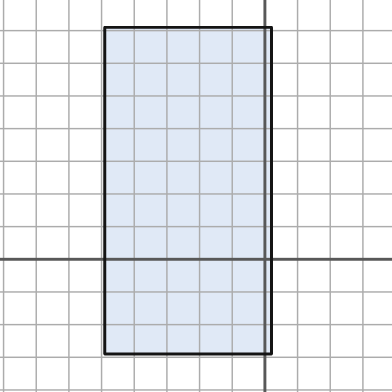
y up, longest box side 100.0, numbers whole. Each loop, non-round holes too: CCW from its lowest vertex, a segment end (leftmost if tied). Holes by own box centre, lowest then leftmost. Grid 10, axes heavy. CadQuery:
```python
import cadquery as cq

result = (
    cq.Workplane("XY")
    .moveTo(-49.0, -29.0)
    .lineTo(2.0, -29.0)
    .lineTo(2.0, 71.0)
    .lineTo(-49.0, 71.0)
    .close()
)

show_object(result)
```